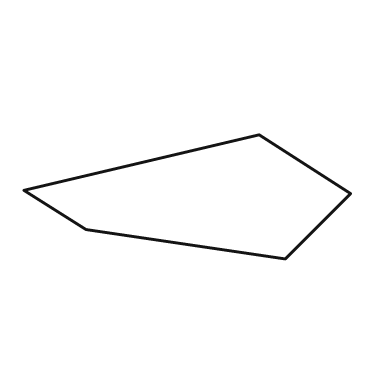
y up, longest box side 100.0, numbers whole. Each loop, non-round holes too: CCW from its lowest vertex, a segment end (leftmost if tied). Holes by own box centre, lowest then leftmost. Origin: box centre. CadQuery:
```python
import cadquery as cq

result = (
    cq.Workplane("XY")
    .moveTo(30.0, -19.0)
    .lineTo(50.0, 1.0)
    .lineTo(22.0, 19.0)
    .lineTo(-50.0, 2.0)
    .lineTo(-31.0, -10.0)
    .close()
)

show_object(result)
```